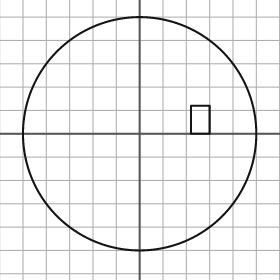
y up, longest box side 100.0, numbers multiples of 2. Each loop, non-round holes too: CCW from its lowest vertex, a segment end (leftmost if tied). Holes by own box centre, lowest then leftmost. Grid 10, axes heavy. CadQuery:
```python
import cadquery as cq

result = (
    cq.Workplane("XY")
    .moveTo(0.0, 0.0)
    .circle(50.0)
    .moveTo(22.0, 0.0)
    .lineTo(30.0, 0.0)
    .lineTo(30.0, 12.0)
    .lineTo(22.0, 12.0)
    .close()
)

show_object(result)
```